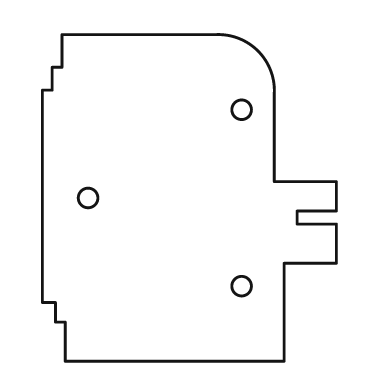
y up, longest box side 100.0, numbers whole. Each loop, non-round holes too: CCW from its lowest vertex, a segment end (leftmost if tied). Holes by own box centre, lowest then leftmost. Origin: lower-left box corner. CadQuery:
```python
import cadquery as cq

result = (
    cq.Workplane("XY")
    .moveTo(7.0, 0.0)
    .lineTo(74.0, 0.0)
    .lineTo(74.0, 30.0)
    .lineTo(90.0, 30.0)
    .lineTo(90.0, 42.0)
    .lineTo(78.0, 42.0)
    .lineTo(78.0, 46.0)
    .lineTo(90.0, 46.0)
    .lineTo(90.0, 55.0)
    .lineTo(71.0, 55.0)
    .lineTo(71.0, 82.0)
    .threePointArc((66.0, 95.0), (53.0, 100.0))
    .lineTo(6.0, 100.0)
    .lineTo(6.0, 90.0)
    .lineTo(3.0, 90.0)
    .lineTo(3.0, 83.0)
    .lineTo(0.0, 83.0)
    .lineTo(0.0, 18.0)
    .lineTo(4.0, 18.0)
    .lineTo(4.0, 12.0)
    .lineTo(7.0, 12.0)
    .close()
    .moveTo(61.0, 23.0)
    .circle(3.0)
    .moveTo(14.0, 50.0)
    .circle(3.0)
    .moveTo(61.0, 77.0)
    .circle(3.0)
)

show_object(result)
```